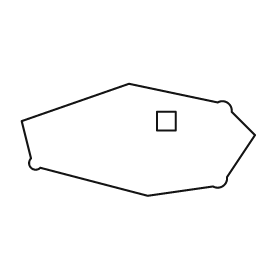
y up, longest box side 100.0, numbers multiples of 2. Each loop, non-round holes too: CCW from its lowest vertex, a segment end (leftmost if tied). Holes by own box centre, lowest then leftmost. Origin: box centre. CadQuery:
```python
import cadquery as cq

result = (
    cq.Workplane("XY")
    .moveTo(4.0, -24.0)
    .lineTo(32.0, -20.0)
    .threePointArc((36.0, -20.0), (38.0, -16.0))
    .lineTo(50.0, 2.0)
    .lineTo(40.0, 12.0)
    .threePointArc((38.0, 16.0), (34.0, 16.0))
    .lineTo(-4.0, 24.0)
    .lineTo(-50.0, 8.0)
    .lineTo(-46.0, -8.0)
    .threePointArc((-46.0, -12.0), (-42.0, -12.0))
    .close()
    .moveTo(8.0, 4.0)
    .lineTo(16.0, 4.0)
    .lineTo(16.0, 12.0)
    .lineTo(8.0, 12.0)
    .close()
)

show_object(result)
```